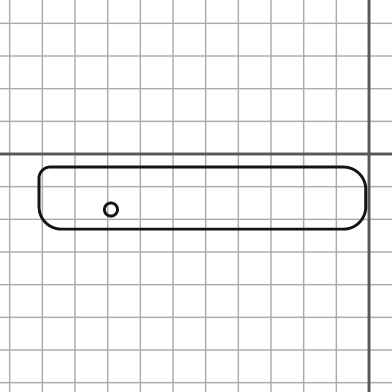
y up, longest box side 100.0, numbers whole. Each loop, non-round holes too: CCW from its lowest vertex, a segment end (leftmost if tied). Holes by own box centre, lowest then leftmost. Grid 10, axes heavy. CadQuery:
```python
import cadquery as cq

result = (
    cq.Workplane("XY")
    .moveTo(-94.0, -23.0)
    .lineTo(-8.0, -23.0)
    .threePointArc((-3.0, -21.0), (-1.0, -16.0))
    .lineTo(-1.0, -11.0)
    .threePointArc((-3.0, -6.0), (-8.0, -4.0))
    .lineTo(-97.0, -4.0)
    .threePointArc((-100.0, -5.0), (-101.0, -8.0))
    .lineTo(-101.0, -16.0)
    .threePointArc((-99.0, -21.0), (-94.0, -23.0))
    .close()
    .moveTo(-79.0, -17.0)
    .circle(2.0)
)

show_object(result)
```